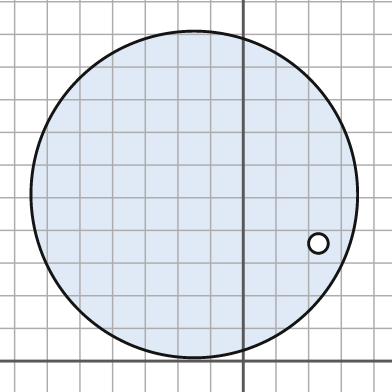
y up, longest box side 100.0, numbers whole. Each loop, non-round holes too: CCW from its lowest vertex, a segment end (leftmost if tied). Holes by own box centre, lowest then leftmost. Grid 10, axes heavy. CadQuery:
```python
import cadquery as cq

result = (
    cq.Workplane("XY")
    .moveTo(-15.0, 51.0)
    .circle(50.0)
    .moveTo(23.0, 36.0)
    .circle(3.0)
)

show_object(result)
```